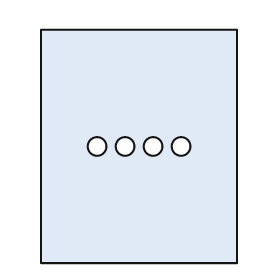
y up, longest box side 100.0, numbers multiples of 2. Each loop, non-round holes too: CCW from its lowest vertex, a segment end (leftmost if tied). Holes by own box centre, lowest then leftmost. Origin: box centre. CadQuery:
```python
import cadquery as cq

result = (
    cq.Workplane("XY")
    .moveTo(-42.0, -50.0)
    .lineTo(42.0, -50.0)
    .lineTo(42.0, 50.0)
    .lineTo(-42.0, 50.0)
    .close()
    .moveTo(-18.0, 0.0)
    .circle(4.0)
    .moveTo(-6.0, 0.0)
    .circle(4.0)
    .moveTo(6.0, 0.0)
    .circle(4.0)
    .moveTo(18.0, 0.0)
    .circle(4.0)
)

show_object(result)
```